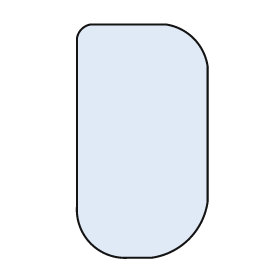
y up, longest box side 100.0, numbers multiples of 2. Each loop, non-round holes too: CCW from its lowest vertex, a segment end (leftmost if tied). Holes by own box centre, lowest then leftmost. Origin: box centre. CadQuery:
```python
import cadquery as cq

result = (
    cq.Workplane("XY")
    .moveTo(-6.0, -50.0)
    .lineTo(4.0, -50.0)
    .threePointArc((20.0, -42.0), (28.0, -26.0))
    .lineTo(28.0, 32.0)
    .threePointArc((22.0, 44.0), (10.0, 50.0))
    .lineTo(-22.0, 50.0)
    .threePointArc((-26.0, 48.0), (-28.0, 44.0))
    .lineTo(-28.0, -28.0)
    .threePointArc((-22.0, -44.0), (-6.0, -50.0))
    .close()
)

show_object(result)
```